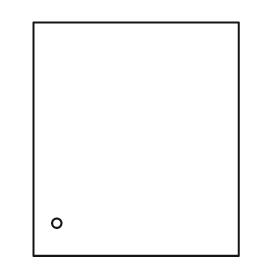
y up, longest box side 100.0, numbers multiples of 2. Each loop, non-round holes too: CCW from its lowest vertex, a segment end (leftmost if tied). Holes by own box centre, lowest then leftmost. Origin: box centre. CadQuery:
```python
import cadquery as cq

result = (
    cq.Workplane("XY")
    .moveTo(-44.0, -50.0)
    .lineTo(44.0, -50.0)
    .lineTo(44.0, 50.0)
    .lineTo(-44.0, 50.0)
    .close()
    .moveTo(-34.0, -36.0)
    .circle(2.0)
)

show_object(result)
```